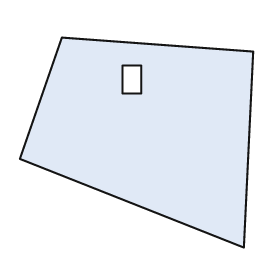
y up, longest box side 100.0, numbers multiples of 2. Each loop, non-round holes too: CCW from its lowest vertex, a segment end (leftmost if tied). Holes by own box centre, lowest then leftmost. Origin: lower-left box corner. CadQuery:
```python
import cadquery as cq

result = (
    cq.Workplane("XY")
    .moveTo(96.0, 0.0)
    .lineTo(100.0, 84.0)
    .lineTo(18.0, 90.0)
    .lineTo(0.0, 38.0)
    .close()
    .moveTo(44.0, 66.0)
    .lineTo(52.0, 66.0)
    .lineTo(52.0, 78.0)
    .lineTo(44.0, 78.0)
    .close()
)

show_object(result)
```